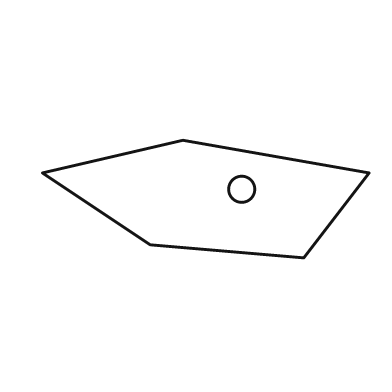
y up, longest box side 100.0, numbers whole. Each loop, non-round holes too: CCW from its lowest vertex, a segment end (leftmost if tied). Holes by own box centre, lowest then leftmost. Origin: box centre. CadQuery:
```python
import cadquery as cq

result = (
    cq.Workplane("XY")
    .moveTo(30.0, -18.0)
    .lineTo(50.0, 8.0)
    .lineTo(-7.0, 18.0)
    .lineTo(-50.0, 8.0)
    .lineTo(-17.0, -14.0)
    .close()
    .moveTo(11.0, 3.0)
    .circle(4.0)
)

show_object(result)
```